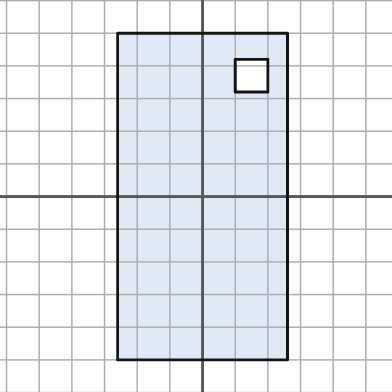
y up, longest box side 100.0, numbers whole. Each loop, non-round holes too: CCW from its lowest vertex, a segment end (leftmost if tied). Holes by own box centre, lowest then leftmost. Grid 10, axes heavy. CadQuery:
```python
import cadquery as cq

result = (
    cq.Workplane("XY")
    .moveTo(-26.0, -50.0)
    .lineTo(26.0, -50.0)
    .lineTo(26.0, 50.0)
    .lineTo(-26.0, 50.0)
    .close()
    .moveTo(10.0, 32.0)
    .lineTo(20.0, 32.0)
    .lineTo(20.0, 42.0)
    .lineTo(10.0, 42.0)
    .close()
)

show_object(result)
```